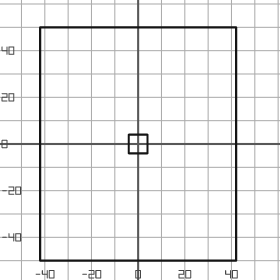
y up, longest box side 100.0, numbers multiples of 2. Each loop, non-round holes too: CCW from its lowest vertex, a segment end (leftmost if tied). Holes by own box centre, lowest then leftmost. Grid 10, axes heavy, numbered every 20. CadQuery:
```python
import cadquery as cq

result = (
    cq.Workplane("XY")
    .moveTo(-42.0, -50.0)
    .lineTo(42.0, -50.0)
    .lineTo(42.0, 50.0)
    .lineTo(-42.0, 50.0)
    .close()
    .moveTo(-4.0, -4.0)
    .lineTo(4.0, -4.0)
    .lineTo(4.0, 4.0)
    .lineTo(-4.0, 4.0)
    .close()
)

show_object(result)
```